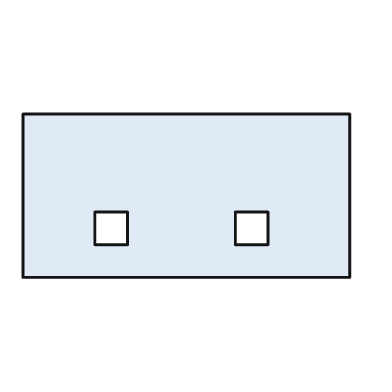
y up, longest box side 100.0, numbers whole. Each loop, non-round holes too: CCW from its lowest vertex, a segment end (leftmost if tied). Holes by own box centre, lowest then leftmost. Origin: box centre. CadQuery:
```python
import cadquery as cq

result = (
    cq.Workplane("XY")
    .moveTo(-50.0, -25.0)
    .lineTo(50.0, -25.0)
    .lineTo(50.0, 25.0)
    .lineTo(-50.0, 25.0)
    .close()
    .moveTo(-28.0, -15.0)
    .lineTo(-18.0, -15.0)
    .lineTo(-18.0, -5.0)
    .lineTo(-28.0, -5.0)
    .close()
    .moveTo(15.0, -15.0)
    .lineTo(25.0, -15.0)
    .lineTo(25.0, -5.0)
    .lineTo(15.0, -5.0)
    .close()
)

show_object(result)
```